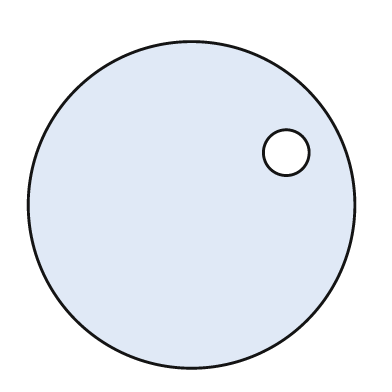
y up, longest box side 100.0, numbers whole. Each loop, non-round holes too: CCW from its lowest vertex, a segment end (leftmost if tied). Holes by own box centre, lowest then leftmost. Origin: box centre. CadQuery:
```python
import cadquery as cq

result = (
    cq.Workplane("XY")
    .moveTo(0.0, 0.0)
    .circle(50.0)
    .moveTo(29.0, 16.0)
    .circle(7.0)
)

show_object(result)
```